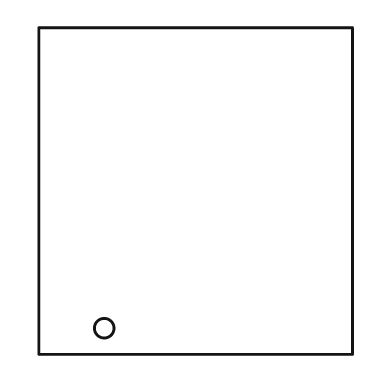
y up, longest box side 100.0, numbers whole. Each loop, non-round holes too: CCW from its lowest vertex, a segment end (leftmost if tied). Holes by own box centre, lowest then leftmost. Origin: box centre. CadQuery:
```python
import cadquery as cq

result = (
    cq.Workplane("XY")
    .moveTo(-48.0, -50.0)
    .lineTo(48.0, -50.0)
    .lineTo(48.0, 50.0)
    .lineTo(-48.0, 50.0)
    .close()
    .moveTo(-28.0, -42.0)
    .circle(3.0)
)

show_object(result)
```